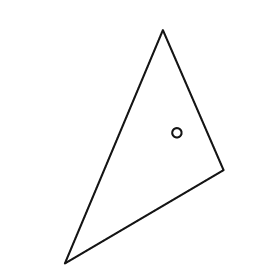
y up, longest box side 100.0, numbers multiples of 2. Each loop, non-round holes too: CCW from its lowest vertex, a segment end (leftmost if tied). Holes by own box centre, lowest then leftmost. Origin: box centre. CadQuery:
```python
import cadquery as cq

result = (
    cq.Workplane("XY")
    .moveTo(-34.0, -50.0)
    .lineTo(34.0, -10.0)
    .lineTo(8.0, 50.0)
    .close()
    .moveTo(14.0, 6.0)
    .circle(2.0)
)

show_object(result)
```